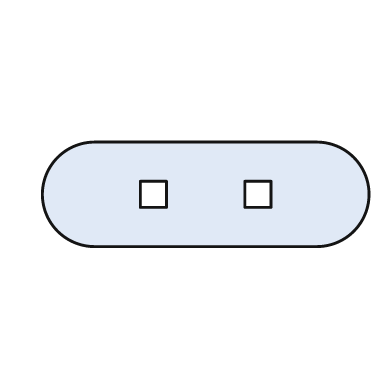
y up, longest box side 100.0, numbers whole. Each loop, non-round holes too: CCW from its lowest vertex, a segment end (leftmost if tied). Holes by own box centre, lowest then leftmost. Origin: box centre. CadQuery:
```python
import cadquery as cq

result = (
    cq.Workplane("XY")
    .moveTo(-34.0, -16.0)
    .lineTo(34.0, -16.0)
    .threePointArc((50.0, 0.0), (34.0, 16.0))
    .lineTo(-34.0, 16.0)
    .threePointArc((-50.0, 0.0), (-34.0, -16.0))
    .close()
    .moveTo(-20.0, -4.0)
    .lineTo(-12.0, -4.0)
    .lineTo(-12.0, 4.0)
    .lineTo(-20.0, 4.0)
    .close()
    .moveTo(12.0, -4.0)
    .lineTo(20.0, -4.0)
    .lineTo(20.0, 4.0)
    .lineTo(12.0, 4.0)
    .close()
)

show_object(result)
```